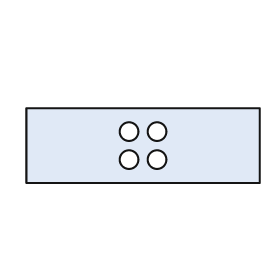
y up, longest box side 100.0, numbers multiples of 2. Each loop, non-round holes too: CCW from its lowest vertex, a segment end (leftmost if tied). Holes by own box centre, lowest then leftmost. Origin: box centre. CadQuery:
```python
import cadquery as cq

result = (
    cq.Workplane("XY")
    .moveTo(-50.0, -16.0)
    .lineTo(50.0, -16.0)
    .lineTo(50.0, 16.0)
    .lineTo(-50.0, 16.0)
    .close()
    .moveTo(-6.0, -6.0)
    .circle(4.0)
    .moveTo(6.0, -6.0)
    .circle(4.0)
    .moveTo(-6.0, 6.0)
    .circle(4.0)
    .moveTo(6.0, 6.0)
    .circle(4.0)
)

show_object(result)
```